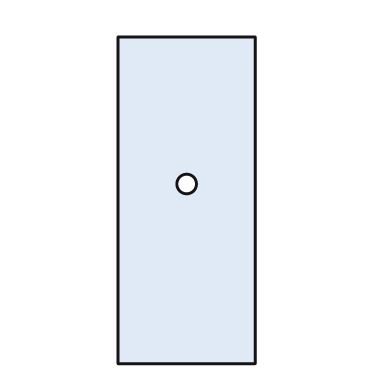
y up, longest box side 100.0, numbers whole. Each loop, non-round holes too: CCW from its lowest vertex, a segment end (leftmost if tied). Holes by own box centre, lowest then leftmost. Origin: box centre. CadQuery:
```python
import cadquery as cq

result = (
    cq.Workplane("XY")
    .moveTo(-21.0, -50.0)
    .lineTo(21.0, -50.0)
    .lineTo(21.0, 50.0)
    .lineTo(-21.0, 50.0)
    .close()
    .moveTo(0.0, 5.0)
    .circle(3.0)
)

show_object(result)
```